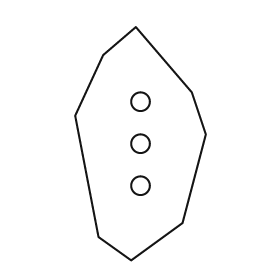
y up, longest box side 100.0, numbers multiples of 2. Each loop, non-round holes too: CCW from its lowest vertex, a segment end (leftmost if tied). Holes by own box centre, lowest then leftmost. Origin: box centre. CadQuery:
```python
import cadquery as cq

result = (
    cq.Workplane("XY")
    .moveTo(-4.0, -50.0)
    .lineTo(18.0, -34.0)
    .lineTo(28.0, 4.0)
    .lineTo(22.0, 22.0)
    .lineTo(-2.0, 50.0)
    .lineTo(-16.0, 38.0)
    .lineTo(-28.0, 12.0)
    .lineTo(-18.0, -40.0)
    .close()
    .moveTo(0.0, -18.0)
    .circle(4.0)
    .moveTo(0.0, 0.0)
    .circle(4.0)
    .moveTo(0.0, 18.0)
    .circle(4.0)
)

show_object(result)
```